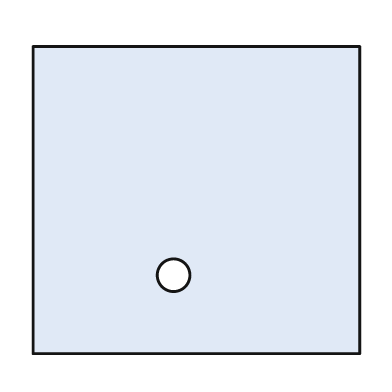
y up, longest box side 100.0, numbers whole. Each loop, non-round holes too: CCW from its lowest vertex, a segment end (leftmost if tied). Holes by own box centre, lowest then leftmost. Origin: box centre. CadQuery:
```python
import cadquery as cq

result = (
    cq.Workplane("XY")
    .moveTo(-50.0, -47.0)
    .lineTo(50.0, -47.0)
    .lineTo(50.0, 47.0)
    .lineTo(-50.0, 47.0)
    .close()
    .moveTo(-7.0, -23.0)
    .circle(5.0)
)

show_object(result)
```